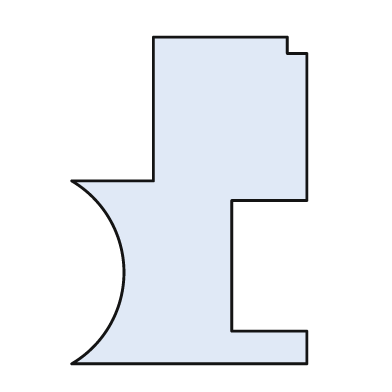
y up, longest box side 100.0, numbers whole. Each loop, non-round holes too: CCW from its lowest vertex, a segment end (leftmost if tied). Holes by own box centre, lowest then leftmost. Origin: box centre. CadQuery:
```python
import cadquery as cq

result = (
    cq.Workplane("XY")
    .moveTo(-36.0, -50.0)
    .lineTo(36.0, -50.0)
    .lineTo(36.0, -40.0)
    .lineTo(13.0, -40.0)
    .lineTo(13.0, 0.0)
    .lineTo(36.0, 0.0)
    .lineTo(36.0, 45.0)
    .lineTo(30.0, 45.0)
    .lineTo(30.0, 50.0)
    .lineTo(-11.0, 50.0)
    .lineTo(-11.0, 6.0)
    .lineTo(-36.0, 6.0)
    .threePointArc((-20.0, -22.0), (-36.0, -50.0))
    .close()
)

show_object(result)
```